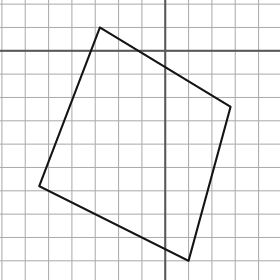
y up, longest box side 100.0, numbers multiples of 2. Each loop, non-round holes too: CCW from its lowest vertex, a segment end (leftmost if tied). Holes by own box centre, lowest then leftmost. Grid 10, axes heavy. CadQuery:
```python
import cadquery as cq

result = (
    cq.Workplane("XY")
    .moveTo(10.0, -90.0)
    .lineTo(28.0, -24.0)
    .lineTo(-28.0, 10.0)
    .lineTo(-54.0, -58.0)
    .close()
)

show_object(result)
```